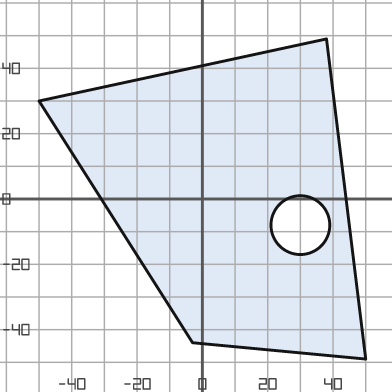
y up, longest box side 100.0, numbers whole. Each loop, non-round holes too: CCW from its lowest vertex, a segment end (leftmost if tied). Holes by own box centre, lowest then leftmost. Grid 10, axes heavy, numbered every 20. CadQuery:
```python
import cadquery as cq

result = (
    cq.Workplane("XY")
    .moveTo(50.0, -49.0)
    .lineTo(38.0, 49.0)
    .lineTo(-50.0, 30.0)
    .lineTo(-3.0, -44.0)
    .close()
    .moveTo(30.0, -8.0)
    .circle(9.0)
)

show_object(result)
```